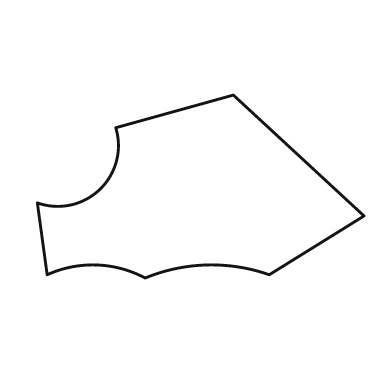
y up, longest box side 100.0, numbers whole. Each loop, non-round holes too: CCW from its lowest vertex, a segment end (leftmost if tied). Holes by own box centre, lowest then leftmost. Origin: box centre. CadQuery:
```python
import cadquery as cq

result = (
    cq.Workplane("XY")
    .moveTo(-17.0, -28.0)
    .threePointArc((2.0, -24.0), (21.0, -27.0))
    .lineTo(50.0, -9.0)
    .lineTo(10.0, 28.0)
    .lineTo(-26.0, 18.0)
    .threePointArc((-31.0, -1.0), (-50.0, -5.0))
    .lineTo(-47.0, -27.0)
    .threePointArc((-32.0, -24.0), (-17.0, -28.0))
    .close()
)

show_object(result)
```